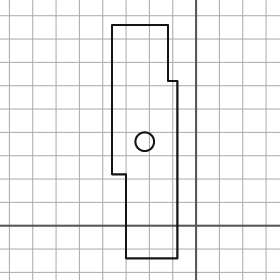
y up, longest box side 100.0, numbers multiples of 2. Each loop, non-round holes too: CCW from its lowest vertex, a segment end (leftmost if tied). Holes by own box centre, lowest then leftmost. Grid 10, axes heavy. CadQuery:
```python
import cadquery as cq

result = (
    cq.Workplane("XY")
    .moveTo(-30.0, -14.0)
    .lineTo(-8.0, -14.0)
    .lineTo(-8.0, 62.0)
    .lineTo(-12.0, 62.0)
    .lineTo(-12.0, 86.0)
    .lineTo(-36.0, 86.0)
    .lineTo(-36.0, 22.0)
    .lineTo(-30.0, 22.0)
    .close()
    .moveTo(-22.0, 36.0)
    .circle(4.0)
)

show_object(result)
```